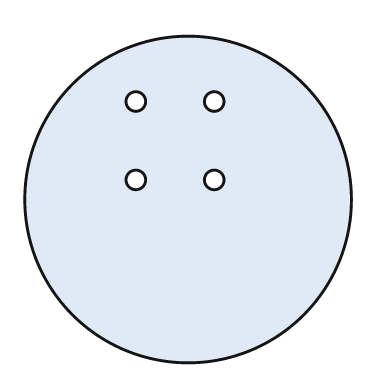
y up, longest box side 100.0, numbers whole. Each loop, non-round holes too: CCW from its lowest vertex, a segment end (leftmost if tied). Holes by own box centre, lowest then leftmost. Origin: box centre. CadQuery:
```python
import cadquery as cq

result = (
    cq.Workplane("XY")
    .moveTo(0.0, 0.0)
    .circle(50.0)
    .moveTo(-16.0, 6.0)
    .circle(3.0)
    .moveTo(8.0, 6.0)
    .circle(3.0)
    .moveTo(-16.0, 30.0)
    .circle(3.0)
    .moveTo(8.0, 30.0)
    .circle(3.0)
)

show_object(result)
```